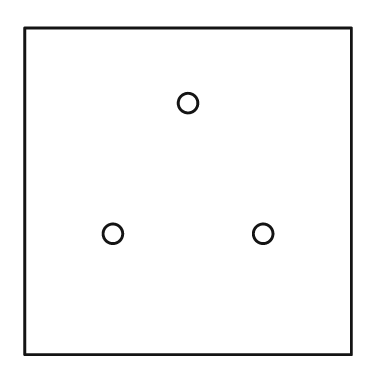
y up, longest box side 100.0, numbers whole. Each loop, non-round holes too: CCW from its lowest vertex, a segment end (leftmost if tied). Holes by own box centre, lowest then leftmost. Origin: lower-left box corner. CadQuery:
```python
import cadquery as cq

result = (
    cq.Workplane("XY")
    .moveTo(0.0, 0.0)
    .lineTo(100.0, 0.0)
    .lineTo(100.0, 100.0)
    .lineTo(0.0, 100.0)
    .close()
    .moveTo(27.0, 37.0)
    .circle(3.0)
    .moveTo(73.0, 37.0)
    .circle(3.0)
    .moveTo(50.0, 77.0)
    .circle(3.0)
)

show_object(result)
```